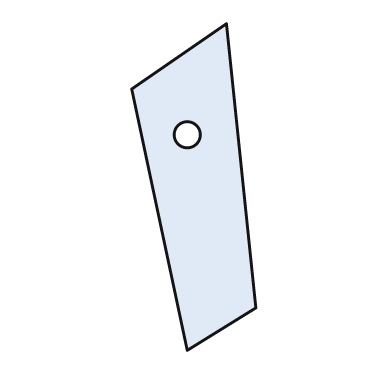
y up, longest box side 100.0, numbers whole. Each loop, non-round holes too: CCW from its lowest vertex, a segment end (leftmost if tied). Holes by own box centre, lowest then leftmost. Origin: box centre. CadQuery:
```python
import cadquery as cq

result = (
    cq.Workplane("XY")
    .moveTo(-2.0, -50.0)
    .lineTo(19.0, -37.0)
    .lineTo(10.0, 50.0)
    .lineTo(-19.0, 30.0)
    .close()
    .moveTo(-2.0, 16.0)
    .circle(4.0)
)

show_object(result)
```